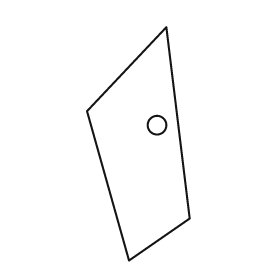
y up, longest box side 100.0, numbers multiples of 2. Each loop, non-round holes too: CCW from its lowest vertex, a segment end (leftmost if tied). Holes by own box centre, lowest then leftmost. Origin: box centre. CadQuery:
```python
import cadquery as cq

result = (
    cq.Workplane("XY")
    .moveTo(-4.0, -50.0)
    .lineTo(22.0, -32.0)
    .lineTo(12.0, 50.0)
    .lineTo(-22.0, 14.0)
    .close()
    .moveTo(8.0, 8.0)
    .circle(4.0)
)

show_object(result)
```